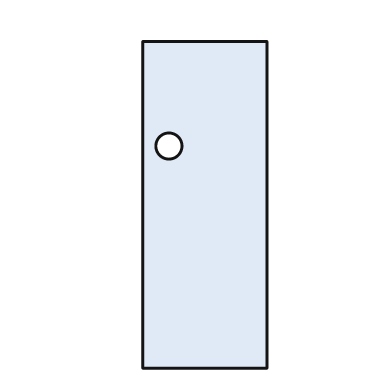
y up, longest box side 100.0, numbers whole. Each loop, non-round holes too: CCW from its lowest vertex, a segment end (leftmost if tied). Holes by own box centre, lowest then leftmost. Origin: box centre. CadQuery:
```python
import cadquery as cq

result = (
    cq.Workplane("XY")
    .moveTo(-19.0, -50.0)
    .lineTo(19.0, -50.0)
    .lineTo(19.0, 50.0)
    .lineTo(-19.0, 50.0)
    .close()
    .moveTo(-11.0, 18.0)
    .circle(4.0)
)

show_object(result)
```